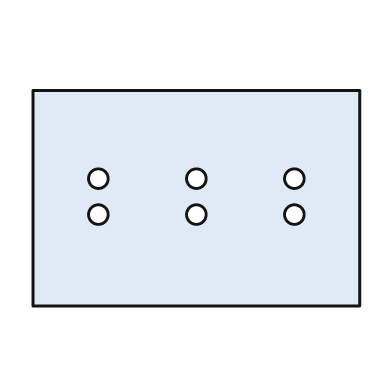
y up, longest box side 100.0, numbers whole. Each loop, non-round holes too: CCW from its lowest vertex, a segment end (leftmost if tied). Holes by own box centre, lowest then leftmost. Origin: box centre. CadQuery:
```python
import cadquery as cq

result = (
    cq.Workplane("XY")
    .moveTo(-50.0, -33.0)
    .lineTo(50.0, -33.0)
    .lineTo(50.0, 33.0)
    .lineTo(-50.0, 33.0)
    .close()
    .moveTo(-30.0, -5.0)
    .circle(3.0)
    .moveTo(0.0, -5.0)
    .circle(3.0)
    .moveTo(30.0, -5.0)
    .circle(3.0)
    .moveTo(-30.0, 6.0)
    .circle(3.0)
    .moveTo(0.0, 6.0)
    .circle(3.0)
    .moveTo(30.0, 6.0)
    .circle(3.0)
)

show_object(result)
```